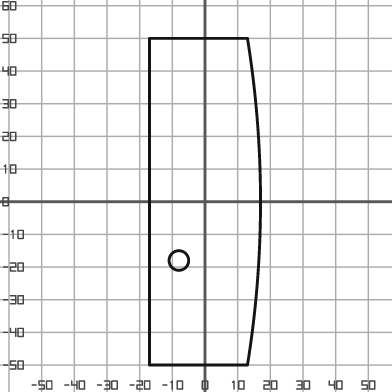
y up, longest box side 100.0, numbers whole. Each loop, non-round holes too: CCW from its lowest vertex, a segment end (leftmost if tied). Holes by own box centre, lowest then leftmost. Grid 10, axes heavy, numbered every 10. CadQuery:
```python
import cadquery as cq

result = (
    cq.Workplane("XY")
    .moveTo(-17.0, -50.0)
    .lineTo(13.0, -50.0)
    .threePointArc((17.0, 0.0), (13.0, 50.0))
    .lineTo(-17.0, 50.0)
    .close()
    .moveTo(-8.0, -18.0)
    .circle(3.0)
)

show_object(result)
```